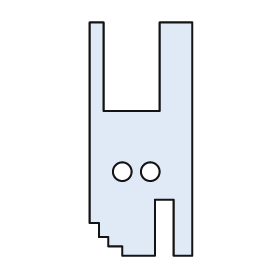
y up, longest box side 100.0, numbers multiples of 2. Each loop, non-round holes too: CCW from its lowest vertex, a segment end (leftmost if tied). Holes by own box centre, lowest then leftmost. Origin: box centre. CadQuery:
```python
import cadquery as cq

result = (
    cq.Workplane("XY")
    .moveTo(-8.0, -50.0)
    .lineTo(6.0, -50.0)
    .lineTo(6.0, -26.0)
    .lineTo(14.0, -26.0)
    .lineTo(14.0, -50.0)
    .lineTo(22.0, -50.0)
    .lineTo(22.0, 50.0)
    .lineTo(8.0, 50.0)
    .lineTo(8.0, 12.0)
    .lineTo(-16.0, 12.0)
    .lineTo(-16.0, 50.0)
    .lineTo(-22.0, 50.0)
    .lineTo(-22.0, -36.0)
    .lineTo(-18.0, -36.0)
    .lineTo(-18.0, -42.0)
    .lineTo(-14.0, -42.0)
    .lineTo(-14.0, -46.0)
    .lineTo(-8.0, -46.0)
    .close()
    .moveTo(-8.0, -14.0)
    .circle(4.0)
    .moveTo(4.0, -14.0)
    .circle(4.0)
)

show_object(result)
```